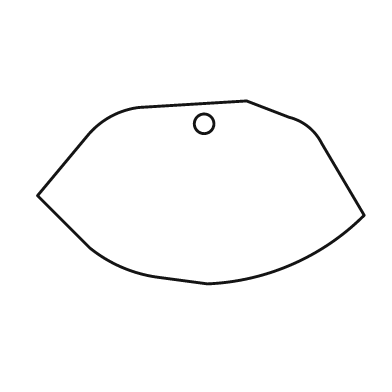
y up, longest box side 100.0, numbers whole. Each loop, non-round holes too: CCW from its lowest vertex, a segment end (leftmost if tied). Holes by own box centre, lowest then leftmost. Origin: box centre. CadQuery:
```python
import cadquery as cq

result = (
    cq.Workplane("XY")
    .moveTo(2.0, -28.0)
    .threePointArc((28.0, -22.0), (50.0, -7.0))
    .lineTo(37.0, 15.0)
    .threePointArc((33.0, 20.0), (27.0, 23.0))
    .lineTo(14.0, 28.0)
    .lineTo(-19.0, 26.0)
    .threePointArc((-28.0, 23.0), (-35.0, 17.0))
    .lineTo(-50.0, -1.0)
    .lineTo(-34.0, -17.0)
    .threePointArc((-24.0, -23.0), (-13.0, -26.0))
    .close()
    .moveTo(1.0, 21.0)
    .circle(3.0)
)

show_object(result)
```